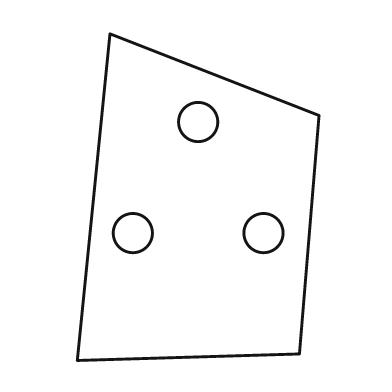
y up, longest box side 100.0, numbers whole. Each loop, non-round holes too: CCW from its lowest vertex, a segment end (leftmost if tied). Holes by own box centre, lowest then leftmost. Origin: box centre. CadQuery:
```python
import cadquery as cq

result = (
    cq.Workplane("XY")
    .moveTo(-37.0, -50.0)
    .lineTo(31.0, -48.0)
    .lineTo(37.0, 25.0)
    .lineTo(-27.0, 50.0)
    .close()
    .moveTo(-20.0, -11.0)
    .circle(6.0)
    .moveTo(20.0, -11.0)
    .circle(6.0)
    .moveTo(0.0, 23.0)
    .circle(6.0)
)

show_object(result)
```